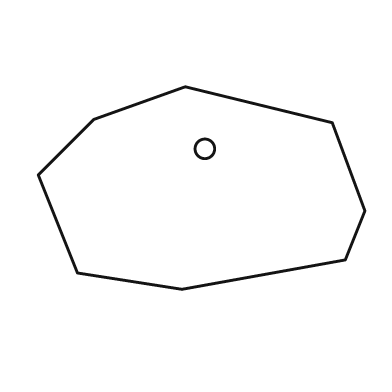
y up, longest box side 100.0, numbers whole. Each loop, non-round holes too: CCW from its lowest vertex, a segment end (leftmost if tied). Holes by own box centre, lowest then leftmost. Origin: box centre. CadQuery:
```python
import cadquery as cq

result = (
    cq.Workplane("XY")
    .moveTo(-6.0, -31.0)
    .lineTo(44.0, -22.0)
    .lineTo(50.0, -7.0)
    .lineTo(40.0, 20.0)
    .lineTo(-5.0, 31.0)
    .lineTo(-33.0, 21.0)
    .lineTo(-50.0, 4.0)
    .lineTo(-38.0, -26.0)
    .close()
    .moveTo(1.0, 12.0)
    .circle(3.0)
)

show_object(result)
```